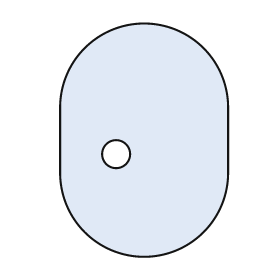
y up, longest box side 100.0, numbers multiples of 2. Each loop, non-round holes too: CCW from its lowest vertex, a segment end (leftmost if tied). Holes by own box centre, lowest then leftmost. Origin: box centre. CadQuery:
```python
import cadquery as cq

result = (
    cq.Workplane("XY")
    .moveTo(-36.0, -14.0)
    .threePointArc((0.0, -50.0), (36.0, -14.0))
    .lineTo(36.0, 14.0)
    .threePointArc((0.0, 50.0), (-36.0, 14.0))
    .close()
    .moveTo(-12.0, -6.0)
    .circle(6.0)
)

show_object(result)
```